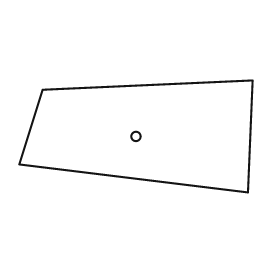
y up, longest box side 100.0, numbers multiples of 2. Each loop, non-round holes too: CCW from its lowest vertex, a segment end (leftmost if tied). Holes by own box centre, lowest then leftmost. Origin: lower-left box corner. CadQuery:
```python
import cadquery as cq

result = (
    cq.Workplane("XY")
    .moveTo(98.0, 0.0)
    .lineTo(100.0, 48.0)
    .lineTo(10.0, 44.0)
    .lineTo(0.0, 12.0)
    .close()
    .moveTo(50.0, 24.0)
    .circle(2.0)
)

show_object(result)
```